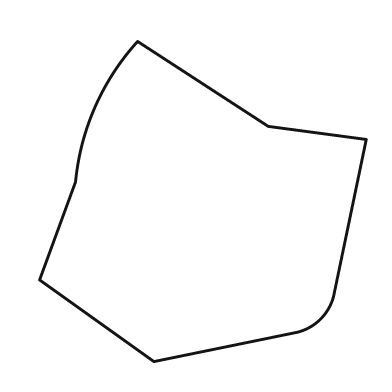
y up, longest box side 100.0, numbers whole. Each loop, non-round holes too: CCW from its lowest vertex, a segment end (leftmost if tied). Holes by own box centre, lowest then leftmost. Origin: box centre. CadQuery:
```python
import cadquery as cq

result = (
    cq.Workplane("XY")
    .moveTo(-15.0, -49.0)
    .lineTo(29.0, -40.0)
    .threePointArc((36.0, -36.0), (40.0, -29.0))
    .lineTo(50.0, 19.0)
    .lineTo(20.0, 23.0)
    .lineTo(-20.0, 49.0)
    .threePointArc((-33.0, 29.0), (-39.0, 6.0))
    .lineTo(-50.0, -24.0)
    .close()
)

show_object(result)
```